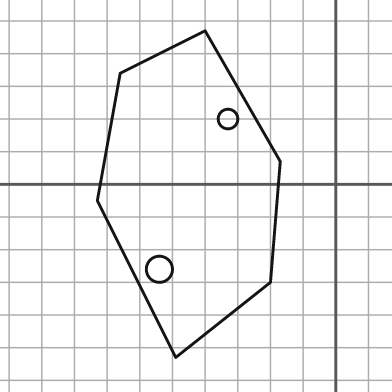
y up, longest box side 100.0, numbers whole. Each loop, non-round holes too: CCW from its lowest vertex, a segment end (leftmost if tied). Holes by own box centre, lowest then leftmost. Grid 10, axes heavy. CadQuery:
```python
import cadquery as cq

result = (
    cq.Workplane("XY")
    .moveTo(-49.0, -53.0)
    .lineTo(-20.0, -30.0)
    .lineTo(-17.0, 7.0)
    .lineTo(-40.0, 47.0)
    .lineTo(-66.0, 34.0)
    .lineTo(-73.0, -5.0)
    .close()
    .moveTo(-54.0, -26.0)
    .circle(4.0)
    .moveTo(-33.0, 20.0)
    .circle(3.0)
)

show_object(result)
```